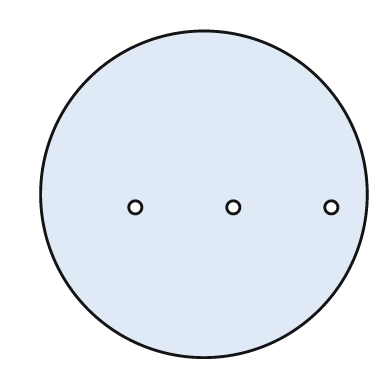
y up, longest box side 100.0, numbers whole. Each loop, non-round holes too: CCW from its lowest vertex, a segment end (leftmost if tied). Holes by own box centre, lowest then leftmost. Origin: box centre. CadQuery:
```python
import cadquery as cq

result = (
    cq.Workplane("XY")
    .moveTo(0.0, 0.0)
    .circle(50.0)
    .moveTo(-21.0, -4.0)
    .circle(2.0)
    .moveTo(9.0, -4.0)
    .circle(2.0)
    .moveTo(39.0, -4.0)
    .circle(2.0)
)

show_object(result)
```